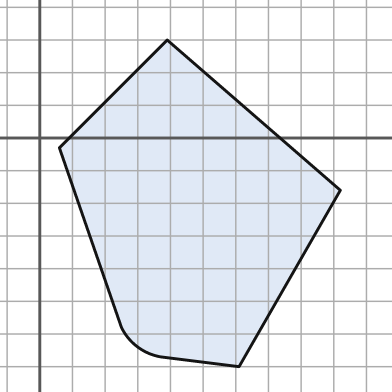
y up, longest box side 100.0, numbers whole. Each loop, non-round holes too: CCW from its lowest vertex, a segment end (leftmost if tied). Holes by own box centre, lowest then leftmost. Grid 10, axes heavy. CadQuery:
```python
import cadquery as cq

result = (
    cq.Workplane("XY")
    .moveTo(61.0, -70.0)
    .lineTo(92.0, -16.0)
    .lineTo(39.0, 30.0)
    .lineTo(6.0, -3.0)
    .lineTo(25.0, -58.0)
    .threePointArc((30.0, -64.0), (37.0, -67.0))
    .close()
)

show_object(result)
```